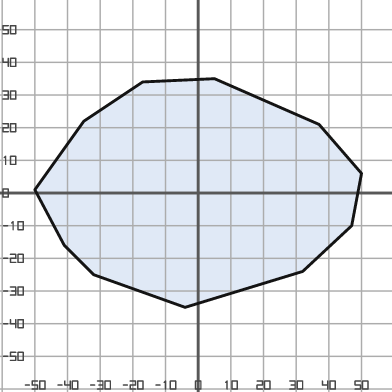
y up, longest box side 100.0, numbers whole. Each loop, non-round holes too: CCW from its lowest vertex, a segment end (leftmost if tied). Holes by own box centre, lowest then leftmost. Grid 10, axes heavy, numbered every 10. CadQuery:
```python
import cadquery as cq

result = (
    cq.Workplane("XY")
    .moveTo(-4.0, -35.0)
    .lineTo(32.0, -24.0)
    .lineTo(47.0, -10.0)
    .lineTo(50.0, 6.0)
    .lineTo(37.0, 21.0)
    .lineTo(5.0, 35.0)
    .lineTo(-17.0, 34.0)
    .lineTo(-35.0, 22.0)
    .lineTo(-50.0, 1.0)
    .lineTo(-41.0, -16.0)
    .lineTo(-32.0, -25.0)
    .close()
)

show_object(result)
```